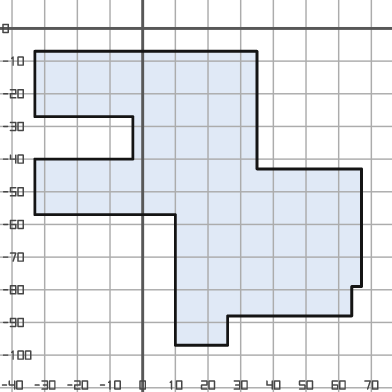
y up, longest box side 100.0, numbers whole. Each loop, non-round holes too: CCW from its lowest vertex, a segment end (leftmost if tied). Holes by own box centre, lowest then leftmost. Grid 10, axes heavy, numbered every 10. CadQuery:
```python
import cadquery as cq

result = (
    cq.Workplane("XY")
    .moveTo(10.0, -97.0)
    .lineTo(26.0, -97.0)
    .lineTo(26.0, -88.0)
    .lineTo(64.0, -88.0)
    .lineTo(64.0, -79.0)
    .lineTo(67.0, -79.0)
    .lineTo(67.0, -43.0)
    .lineTo(35.0, -43.0)
    .lineTo(35.0, -7.0)
    .lineTo(-33.0, -7.0)
    .lineTo(-33.0, -27.0)
    .lineTo(-3.0, -27.0)
    .lineTo(-3.0, -40.0)
    .lineTo(-33.0, -40.0)
    .lineTo(-33.0, -57.0)
    .lineTo(10.0, -57.0)
    .close()
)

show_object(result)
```